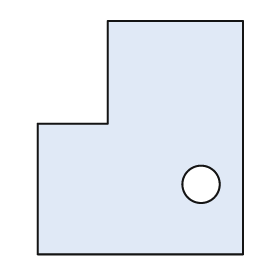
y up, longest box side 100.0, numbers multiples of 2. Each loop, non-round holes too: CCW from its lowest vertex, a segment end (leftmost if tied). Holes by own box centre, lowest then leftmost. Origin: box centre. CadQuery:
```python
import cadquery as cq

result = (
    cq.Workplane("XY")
    .moveTo(-44.0, -50.0)
    .lineTo(44.0, -50.0)
    .lineTo(44.0, 50.0)
    .lineTo(-14.0, 50.0)
    .lineTo(-14.0, 6.0)
    .lineTo(-44.0, 6.0)
    .close()
    .moveTo(26.0, -20.0)
    .circle(8.0)
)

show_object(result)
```